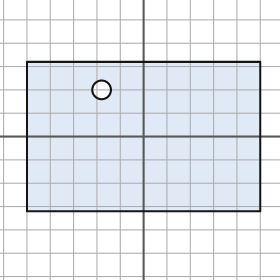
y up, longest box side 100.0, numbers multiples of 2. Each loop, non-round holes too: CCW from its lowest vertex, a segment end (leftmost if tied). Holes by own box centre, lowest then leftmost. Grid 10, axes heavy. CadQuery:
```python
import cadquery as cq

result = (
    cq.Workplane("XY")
    .moveTo(-50.0, -32.0)
    .lineTo(50.0, -32.0)
    .lineTo(50.0, 32.0)
    .lineTo(-50.0, 32.0)
    .close()
    .moveTo(-18.0, 20.0)
    .circle(4.0)
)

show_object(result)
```